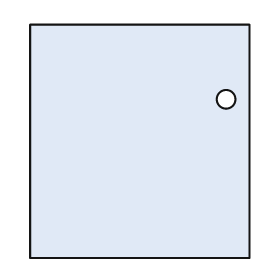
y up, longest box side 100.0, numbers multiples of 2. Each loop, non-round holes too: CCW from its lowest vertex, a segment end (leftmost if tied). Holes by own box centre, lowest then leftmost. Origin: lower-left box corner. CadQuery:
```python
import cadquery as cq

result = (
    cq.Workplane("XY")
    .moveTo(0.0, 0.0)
    .lineTo(94.0, 0.0)
    .lineTo(94.0, 100.0)
    .lineTo(0.0, 100.0)
    .close()
    .moveTo(84.0, 68.0)
    .circle(4.0)
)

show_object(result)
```